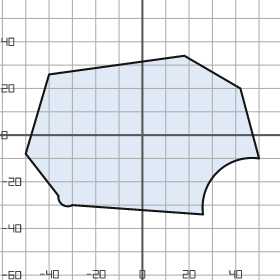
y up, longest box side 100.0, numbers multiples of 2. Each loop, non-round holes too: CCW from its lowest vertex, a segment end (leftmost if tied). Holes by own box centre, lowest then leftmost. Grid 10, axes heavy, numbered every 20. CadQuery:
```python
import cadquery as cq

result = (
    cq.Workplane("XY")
    .moveTo(26.0, -34.0)
    .threePointArc((32.0, -16.0), (50.0, -10.0))
    .lineTo(42.0, 20.0)
    .lineTo(18.0, 34.0)
    .lineTo(-40.0, 26.0)
    .lineTo(-50.0, -8.0)
    .lineTo(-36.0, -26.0)
    .threePointArc((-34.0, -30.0), (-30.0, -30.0))
    .close()
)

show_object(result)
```